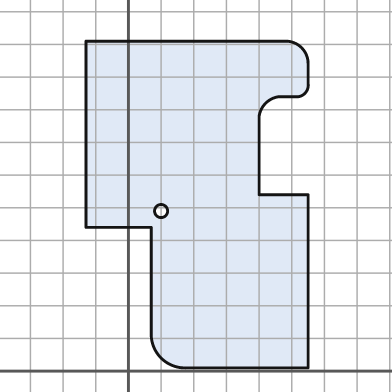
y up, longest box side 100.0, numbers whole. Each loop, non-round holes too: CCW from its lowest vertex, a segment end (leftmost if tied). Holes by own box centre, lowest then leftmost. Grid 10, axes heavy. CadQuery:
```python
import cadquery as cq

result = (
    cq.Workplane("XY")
    .moveTo(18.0, 1.0)
    .lineTo(55.0, 1.0)
    .lineTo(55.0, 54.0)
    .lineTo(40.0, 54.0)
    .lineTo(40.0, 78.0)
    .threePointArc((42.0, 82.0), (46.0, 84.0))
    .lineTo(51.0, 84.0)
    .threePointArc((54.0, 85.0), (55.0, 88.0))
    .lineTo(55.0, 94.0)
    .threePointArc((53.0, 99.0), (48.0, 101.0))
    .lineTo(-13.0, 101.0)
    .lineTo(-13.0, 44.0)
    .lineTo(7.0, 44.0)
    .lineTo(7.0, 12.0)
    .threePointArc((10.0, 4.0), (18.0, 1.0))
    .close()
    .moveTo(10.0, 49.0)
    .circle(2.0)
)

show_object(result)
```